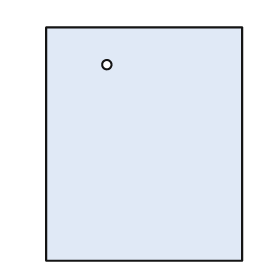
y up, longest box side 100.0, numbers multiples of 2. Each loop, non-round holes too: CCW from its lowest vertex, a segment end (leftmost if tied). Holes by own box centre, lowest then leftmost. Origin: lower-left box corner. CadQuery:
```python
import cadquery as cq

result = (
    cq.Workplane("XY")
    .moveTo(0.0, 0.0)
    .lineTo(84.0, 0.0)
    .lineTo(84.0, 100.0)
    .lineTo(0.0, 100.0)
    .close()
    .moveTo(26.0, 84.0)
    .circle(2.0)
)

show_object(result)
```